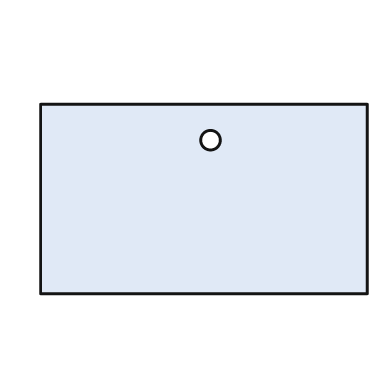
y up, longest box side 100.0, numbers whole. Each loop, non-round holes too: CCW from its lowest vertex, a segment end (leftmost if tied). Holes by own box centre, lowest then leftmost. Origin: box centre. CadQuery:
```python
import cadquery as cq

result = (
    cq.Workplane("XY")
    .moveTo(-50.0, -29.0)
    .lineTo(50.0, -29.0)
    .lineTo(50.0, 29.0)
    .lineTo(-50.0, 29.0)
    .close()
    .moveTo(2.0, 18.0)
    .circle(3.0)
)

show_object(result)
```